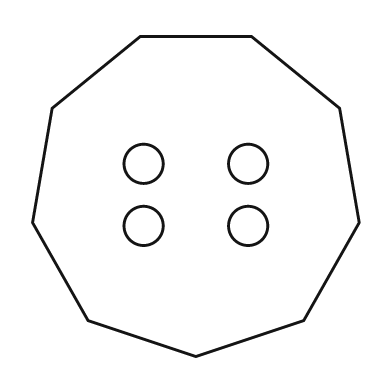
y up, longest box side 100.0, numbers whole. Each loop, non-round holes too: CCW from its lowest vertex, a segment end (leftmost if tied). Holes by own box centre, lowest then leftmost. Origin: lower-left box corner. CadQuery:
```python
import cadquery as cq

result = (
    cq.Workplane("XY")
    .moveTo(50.0, 0.0)
    .lineTo(83.0, 11.0)
    .lineTo(100.0, 41.0)
    .lineTo(94.0, 76.0)
    .lineTo(67.0, 98.0)
    .lineTo(33.0, 98.0)
    .lineTo(6.0, 76.0)
    .lineTo(0.0, 41.0)
    .lineTo(17.0, 11.0)
    .close()
    .moveTo(34.0, 40.0)
    .circle(6.0)
    .moveTo(66.0, 40.0)
    .circle(6.0)
    .moveTo(34.0, 59.0)
    .circle(6.0)
    .moveTo(66.0, 59.0)
    .circle(6.0)
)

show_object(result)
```